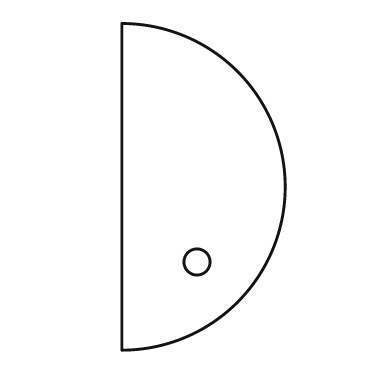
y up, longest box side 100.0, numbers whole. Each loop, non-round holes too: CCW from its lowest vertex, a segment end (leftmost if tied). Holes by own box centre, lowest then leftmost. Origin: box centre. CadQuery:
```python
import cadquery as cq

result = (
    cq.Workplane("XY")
    .moveTo(-25.0, -50.0)
    .threePointArc((25.0, 0.0), (-25.0, 50.0))
    .close()
    .moveTo(-2.0, -23.0)
    .circle(4.0)
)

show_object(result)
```